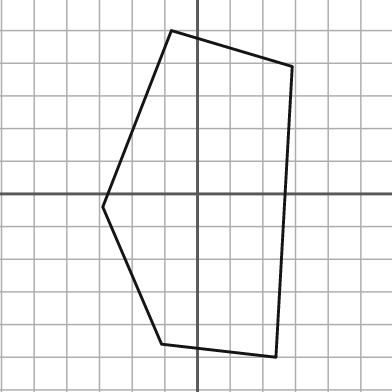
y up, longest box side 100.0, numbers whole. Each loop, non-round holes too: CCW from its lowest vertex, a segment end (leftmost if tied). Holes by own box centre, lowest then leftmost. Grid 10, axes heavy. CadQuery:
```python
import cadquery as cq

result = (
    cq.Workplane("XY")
    .moveTo(24.0, -50.0)
    .lineTo(29.0, 39.0)
    .lineTo(-8.0, 50.0)
    .lineTo(-29.0, -4.0)
    .lineTo(-11.0, -46.0)
    .close()
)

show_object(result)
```